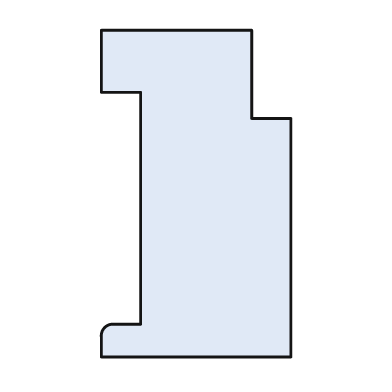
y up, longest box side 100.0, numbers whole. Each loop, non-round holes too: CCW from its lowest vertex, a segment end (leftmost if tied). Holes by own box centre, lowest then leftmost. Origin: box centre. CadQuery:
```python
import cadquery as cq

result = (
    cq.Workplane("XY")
    .moveTo(-29.0, -50.0)
    .lineTo(29.0, -50.0)
    .lineTo(29.0, 23.0)
    .lineTo(17.0, 23.0)
    .lineTo(17.0, 50.0)
    .lineTo(-29.0, 50.0)
    .lineTo(-29.0, 31.0)
    .lineTo(-17.0, 31.0)
    .lineTo(-17.0, -40.0)
    .lineTo(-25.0, -40.0)
    .threePointArc((-28.0, -41.0), (-29.0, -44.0))
    .close()
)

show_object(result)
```